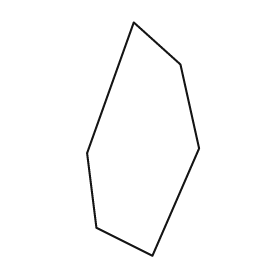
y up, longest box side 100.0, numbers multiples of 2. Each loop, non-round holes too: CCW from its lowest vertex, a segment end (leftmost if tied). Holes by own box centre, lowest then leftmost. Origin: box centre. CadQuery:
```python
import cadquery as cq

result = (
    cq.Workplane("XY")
    .moveTo(4.0, -50.0)
    .lineTo(24.0, -4.0)
    .lineTo(16.0, 32.0)
    .lineTo(-4.0, 50.0)
    .lineTo(-24.0, -6.0)
    .lineTo(-20.0, -38.0)
    .close()
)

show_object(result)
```